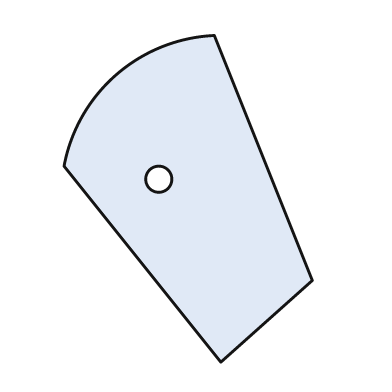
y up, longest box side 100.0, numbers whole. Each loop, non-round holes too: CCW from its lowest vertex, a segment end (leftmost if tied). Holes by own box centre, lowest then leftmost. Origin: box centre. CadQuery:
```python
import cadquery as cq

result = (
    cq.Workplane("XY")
    .moveTo(10.0, -50.0)
    .lineTo(38.0, -25.0)
    .lineTo(8.0, 50.0)
    .threePointArc((-22.0, 38.0), (-38.0, 10.0))
    .close()
    .moveTo(-9.0, 6.0)
    .circle(4.0)
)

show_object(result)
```